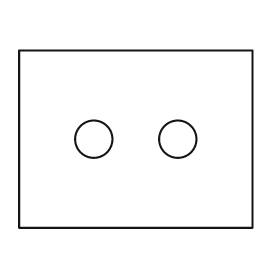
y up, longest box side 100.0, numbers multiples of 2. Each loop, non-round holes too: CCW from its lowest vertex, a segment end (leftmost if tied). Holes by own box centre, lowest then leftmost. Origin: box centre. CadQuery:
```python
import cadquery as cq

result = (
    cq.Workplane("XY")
    .moveTo(-50.0, -38.0)
    .lineTo(50.0, -38.0)
    .lineTo(50.0, 38.0)
    .lineTo(-50.0, 38.0)
    .close()
    .moveTo(-18.0, 0.0)
    .circle(8.0)
    .moveTo(18.0, 0.0)
    .circle(8.0)
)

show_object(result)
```